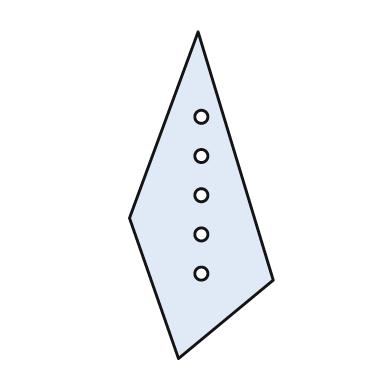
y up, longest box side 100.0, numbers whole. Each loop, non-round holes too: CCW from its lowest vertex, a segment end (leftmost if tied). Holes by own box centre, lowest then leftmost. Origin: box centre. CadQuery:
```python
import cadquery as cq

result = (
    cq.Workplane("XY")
    .moveTo(-7.0, -50.0)
    .lineTo(22.0, -26.0)
    .lineTo(-1.0, 50.0)
    .lineTo(-22.0, -7.0)
    .close()
    .moveTo(0.0, -24.0)
    .circle(2.0)
    .moveTo(0.0, -12.0)
    .circle(2.0)
    .moveTo(0.0, 0.0)
    .circle(2.0)
    .moveTo(0.0, 12.0)
    .circle(2.0)
    .moveTo(0.0, 24.0)
    .circle(2.0)
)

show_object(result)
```